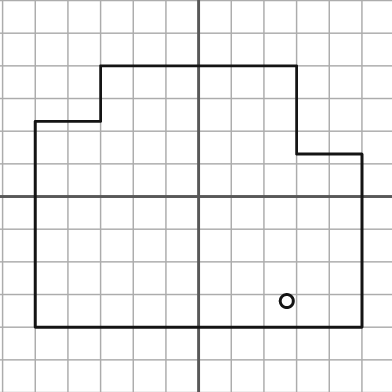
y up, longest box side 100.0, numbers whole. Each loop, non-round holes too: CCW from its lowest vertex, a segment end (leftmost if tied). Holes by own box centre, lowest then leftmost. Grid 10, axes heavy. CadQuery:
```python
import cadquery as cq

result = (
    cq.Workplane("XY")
    .moveTo(-50.0, -40.0)
    .lineTo(50.0, -40.0)
    .lineTo(50.0, 13.0)
    .lineTo(30.0, 13.0)
    .lineTo(30.0, 40.0)
    .lineTo(-30.0, 40.0)
    .lineTo(-30.0, 23.0)
    .lineTo(-50.0, 23.0)
    .close()
    .moveTo(27.0, -32.0)
    .circle(2.0)
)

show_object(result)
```